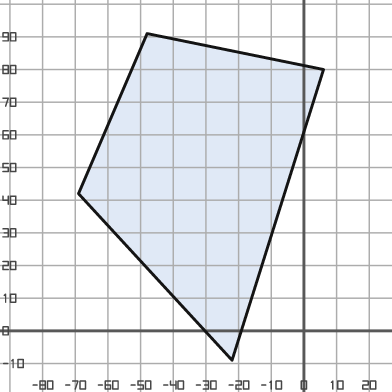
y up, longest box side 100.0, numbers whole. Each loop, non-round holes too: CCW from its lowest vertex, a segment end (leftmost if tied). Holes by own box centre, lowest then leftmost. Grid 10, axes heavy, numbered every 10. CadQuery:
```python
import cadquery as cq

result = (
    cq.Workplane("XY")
    .moveTo(-22.0, -9.0)
    .lineTo(6.0, 80.0)
    .lineTo(-48.0, 91.0)
    .lineTo(-69.0, 42.0)
    .close()
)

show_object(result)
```